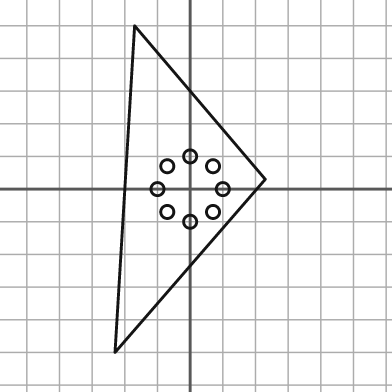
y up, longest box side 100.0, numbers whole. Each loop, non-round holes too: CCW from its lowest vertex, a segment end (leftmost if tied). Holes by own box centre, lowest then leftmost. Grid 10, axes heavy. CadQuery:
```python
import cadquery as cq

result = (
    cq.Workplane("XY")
    .moveTo(-23.0, -50.0)
    .lineTo(23.0, 3.0)
    .lineTo(-17.0, 50.0)
    .close()
    .moveTo(0.0, -10.0)
    .circle(2.0)
    .moveTo(-7.0, -7.0)
    .circle(2.0)
    .moveTo(7.0, -7.0)
    .circle(2.0)
    .moveTo(-10.0, 0.0)
    .circle(2.0)
    .moveTo(10.0, 0.0)
    .circle(2.0)
    .moveTo(-7.0, 7.0)
    .circle(2.0)
    .moveTo(7.0, 7.0)
    .circle(2.0)
    .moveTo(0.0, 10.0)
    .circle(2.0)
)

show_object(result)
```